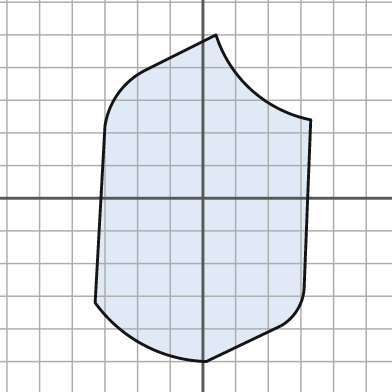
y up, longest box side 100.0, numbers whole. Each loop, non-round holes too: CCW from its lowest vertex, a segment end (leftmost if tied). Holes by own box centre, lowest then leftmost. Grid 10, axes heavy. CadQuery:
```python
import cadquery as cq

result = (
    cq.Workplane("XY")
    .moveTo(1.0, -50.0)
    .lineTo(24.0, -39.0)
    .threePointArc((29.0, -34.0), (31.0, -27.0))
    .lineTo(33.0, 24.0)
    .threePointArc((15.0, 33.0), (4.0, 50.0))
    .lineTo(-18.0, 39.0)
    .threePointArc((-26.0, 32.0), (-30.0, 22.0))
    .lineTo(-33.0, -32.0)
    .threePointArc((-18.0, -45.0), (1.0, -50.0))
    .close()
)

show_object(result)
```